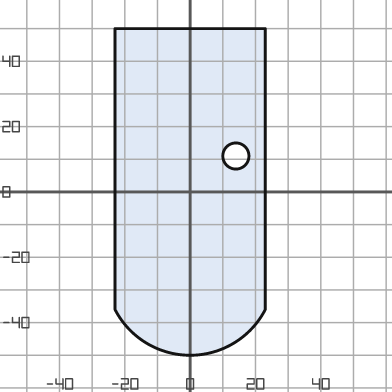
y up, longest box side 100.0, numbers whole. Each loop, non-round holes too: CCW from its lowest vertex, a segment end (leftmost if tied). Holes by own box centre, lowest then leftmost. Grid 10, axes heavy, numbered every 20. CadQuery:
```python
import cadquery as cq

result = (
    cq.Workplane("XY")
    .moveTo(-23.0, -36.0)
    .threePointArc((0.0, -50.0), (23.0, -36.0))
    .lineTo(23.0, 50.0)
    .lineTo(-23.0, 50.0)
    .close()
    .moveTo(14.0, 11.0)
    .circle(4.0)
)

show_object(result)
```